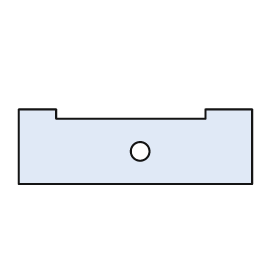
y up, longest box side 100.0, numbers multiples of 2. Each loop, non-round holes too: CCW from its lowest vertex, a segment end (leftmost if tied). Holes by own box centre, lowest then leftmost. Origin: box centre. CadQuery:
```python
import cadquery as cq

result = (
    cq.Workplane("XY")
    .moveTo(-50.0, -16.0)
    .lineTo(50.0, -16.0)
    .lineTo(50.0, 16.0)
    .lineTo(30.0, 16.0)
    .lineTo(30.0, 12.0)
    .lineTo(-34.0, 12.0)
    .lineTo(-34.0, 16.0)
    .lineTo(-50.0, 16.0)
    .close()
    .moveTo(2.0, -2.0)
    .circle(4.0)
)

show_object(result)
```